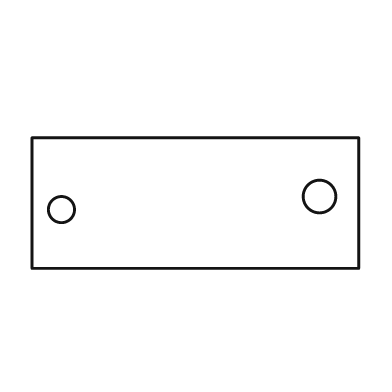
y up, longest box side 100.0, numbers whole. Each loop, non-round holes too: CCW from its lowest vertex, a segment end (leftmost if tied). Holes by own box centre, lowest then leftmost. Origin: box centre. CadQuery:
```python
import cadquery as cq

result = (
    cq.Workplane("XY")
    .moveTo(-50.0, -20.0)
    .lineTo(50.0, -20.0)
    .lineTo(50.0, 20.0)
    .lineTo(-50.0, 20.0)
    .close()
    .moveTo(-41.0, -2.0)
    .circle(4.0)
    .moveTo(38.0, 2.0)
    .circle(5.0)
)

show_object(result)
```